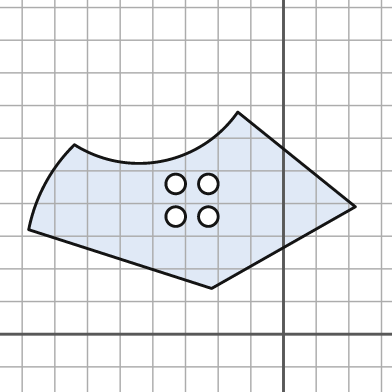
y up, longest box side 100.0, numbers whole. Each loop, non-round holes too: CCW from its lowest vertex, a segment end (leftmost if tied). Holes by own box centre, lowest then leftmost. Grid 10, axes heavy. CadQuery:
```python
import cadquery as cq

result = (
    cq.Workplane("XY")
    .moveTo(-22.0, 14.0)
    .lineTo(22.0, 39.0)
    .lineTo(-14.0, 68.0)
    .threePointArc((-37.0, 53.0), (-64.0, 58.0))
    .threePointArc((-73.0, 46.0), (-78.0, 32.0))
    .close()
    .moveTo(-33.0, 36.0)
    .circle(3.0)
    .moveTo(-23.0, 36.0)
    .circle(3.0)
    .moveTo(-33.0, 46.0)
    .circle(3.0)
    .moveTo(-23.0, 46.0)
    .circle(3.0)
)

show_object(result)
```